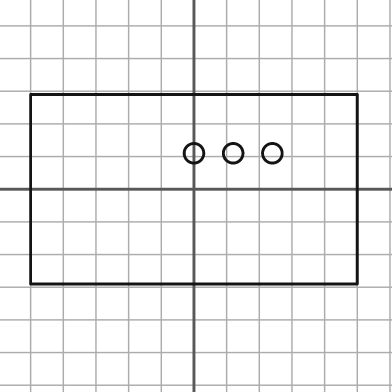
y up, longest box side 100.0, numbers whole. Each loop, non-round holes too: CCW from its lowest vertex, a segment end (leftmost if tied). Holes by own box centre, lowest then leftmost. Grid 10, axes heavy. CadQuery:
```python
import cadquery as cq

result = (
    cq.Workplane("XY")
    .moveTo(-50.0, -29.0)
    .lineTo(50.0, -29.0)
    .lineTo(50.0, 29.0)
    .lineTo(-50.0, 29.0)
    .close()
    .moveTo(0.0, 11.0)
    .circle(3.0)
    .moveTo(12.0, 11.0)
    .circle(3.0)
    .moveTo(24.0, 11.0)
    .circle(3.0)
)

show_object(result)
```